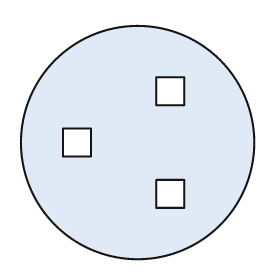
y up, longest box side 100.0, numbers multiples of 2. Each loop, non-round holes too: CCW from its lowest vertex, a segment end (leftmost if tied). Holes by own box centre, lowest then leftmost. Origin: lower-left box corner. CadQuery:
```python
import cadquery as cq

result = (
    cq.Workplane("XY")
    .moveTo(50.0, 50.0)
    .circle(50.0)
    .moveTo(58.0, 22.0)
    .lineTo(70.0, 22.0)
    .lineTo(70.0, 34.0)
    .lineTo(58.0, 34.0)
    .close()
    .moveTo(18.0, 44.0)
    .lineTo(30.0, 44.0)
    .lineTo(30.0, 56.0)
    .lineTo(18.0, 56.0)
    .close()
    .moveTo(58.0, 66.0)
    .lineTo(70.0, 66.0)
    .lineTo(70.0, 78.0)
    .lineTo(58.0, 78.0)
    .close()
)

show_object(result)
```